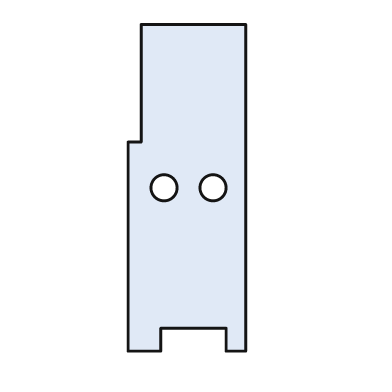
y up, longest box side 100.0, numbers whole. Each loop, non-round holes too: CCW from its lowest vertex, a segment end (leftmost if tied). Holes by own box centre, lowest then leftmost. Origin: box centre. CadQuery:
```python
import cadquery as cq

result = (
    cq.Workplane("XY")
    .moveTo(-18.0, -50.0)
    .lineTo(-8.0, -50.0)
    .lineTo(-8.0, -43.0)
    .lineTo(12.0, -43.0)
    .lineTo(12.0, -50.0)
    .lineTo(18.0, -50.0)
    .lineTo(18.0, 50.0)
    .lineTo(-14.0, 50.0)
    .lineTo(-14.0, 14.0)
    .lineTo(-18.0, 14.0)
    .close()
    .moveTo(-7.0, 0.0)
    .circle(4.0)
    .moveTo(8.0, 0.0)
    .circle(4.0)
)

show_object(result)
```